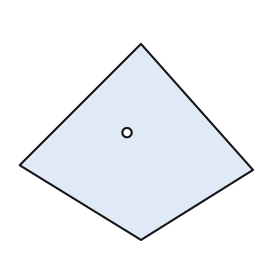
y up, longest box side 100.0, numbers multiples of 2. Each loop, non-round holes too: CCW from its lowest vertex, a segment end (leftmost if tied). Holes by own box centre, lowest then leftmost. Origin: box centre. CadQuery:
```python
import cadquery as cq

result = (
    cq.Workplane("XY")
    .moveTo(2.0, -42.0)
    .lineTo(50.0, -12.0)
    .lineTo(2.0, 42.0)
    .lineTo(-50.0, -10.0)
    .close()
    .moveTo(-4.0, 4.0)
    .circle(2.0)
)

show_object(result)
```